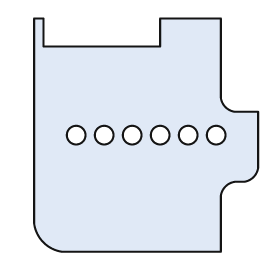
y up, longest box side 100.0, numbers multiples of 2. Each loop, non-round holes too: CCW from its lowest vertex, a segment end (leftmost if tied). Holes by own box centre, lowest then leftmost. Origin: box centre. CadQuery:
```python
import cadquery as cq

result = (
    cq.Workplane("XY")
    .moveTo(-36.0, -50.0)
    .lineTo(32.0, -50.0)
    .lineTo(32.0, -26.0)
    .threePointArc((34.0, -22.0), (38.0, -20.0))
    .lineTo(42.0, -20.0)
    .threePointArc((46.0, -18.0), (48.0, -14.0))
    .lineTo(48.0, 10.0)
    .lineTo(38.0, 10.0)
    .threePointArc((34.0, 12.0), (32.0, 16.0))
    .lineTo(32.0, 50.0)
    .lineTo(6.0, 50.0)
    .lineTo(6.0, 38.0)
    .lineTo(-44.0, 38.0)
    .lineTo(-44.0, 50.0)
    .lineTo(-48.0, 50.0)
    .lineTo(-48.0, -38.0)
    .threePointArc((-44.0, -46.0), (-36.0, -50.0))
    .close()
    .moveTo(-30.0, 0.0)
    .circle(4.0)
    .moveTo(-18.0, 0.0)
    .circle(4.0)
    .moveTo(-6.0, 0.0)
    .circle(4.0)
    .moveTo(6.0, 0.0)
    .circle(4.0)
    .moveTo(18.0, 0.0)
    .circle(4.0)
    .moveTo(30.0, 0.0)
    .circle(4.0)
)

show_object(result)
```